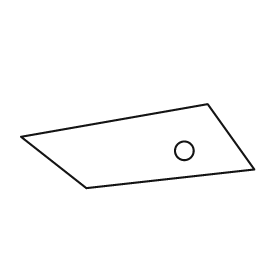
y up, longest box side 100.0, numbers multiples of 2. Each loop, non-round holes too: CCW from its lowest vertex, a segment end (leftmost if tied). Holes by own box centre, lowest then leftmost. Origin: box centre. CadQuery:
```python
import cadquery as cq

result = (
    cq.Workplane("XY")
    .moveTo(-22.0, -18.0)
    .lineTo(50.0, -10.0)
    .lineTo(30.0, 18.0)
    .lineTo(-50.0, 4.0)
    .close()
    .moveTo(20.0, -2.0)
    .circle(4.0)
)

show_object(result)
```